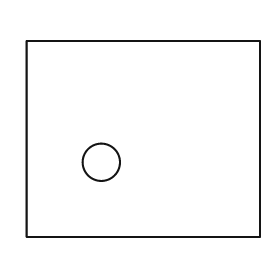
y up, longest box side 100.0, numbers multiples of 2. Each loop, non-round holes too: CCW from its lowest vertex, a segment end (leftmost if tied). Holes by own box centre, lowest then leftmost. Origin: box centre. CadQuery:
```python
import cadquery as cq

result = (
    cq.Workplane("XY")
    .moveTo(-50.0, -42.0)
    .lineTo(50.0, -42.0)
    .lineTo(50.0, 42.0)
    .lineTo(-50.0, 42.0)
    .close()
    .moveTo(-18.0, -10.0)
    .circle(8.0)
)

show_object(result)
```